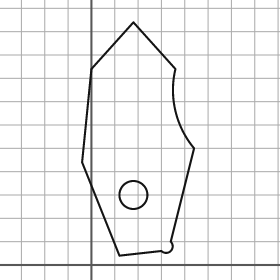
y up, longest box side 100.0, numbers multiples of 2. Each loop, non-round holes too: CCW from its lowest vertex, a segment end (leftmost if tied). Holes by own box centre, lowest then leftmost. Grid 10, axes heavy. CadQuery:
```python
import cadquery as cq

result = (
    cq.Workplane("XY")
    .moveTo(12.0, 4.0)
    .lineTo(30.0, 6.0)
    .threePointArc((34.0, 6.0), (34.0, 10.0))
    .lineTo(44.0, 50.0)
    .threePointArc((36.0, 66.0), (36.0, 84.0))
    .lineTo(18.0, 104.0)
    .lineTo(0.0, 84.0)
    .lineTo(-4.0, 44.0)
    .close()
    .moveTo(18.0, 30.0)
    .circle(6.0)
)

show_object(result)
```